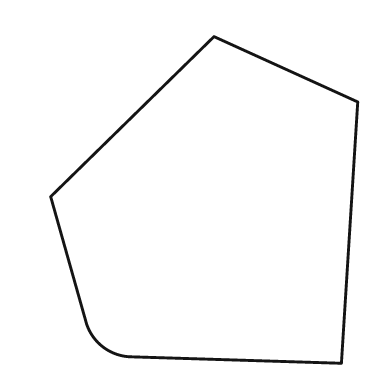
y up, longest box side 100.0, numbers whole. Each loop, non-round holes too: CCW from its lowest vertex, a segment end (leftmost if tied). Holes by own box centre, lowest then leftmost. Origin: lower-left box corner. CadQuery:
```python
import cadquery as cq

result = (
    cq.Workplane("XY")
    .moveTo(89.0, 0.0)
    .lineTo(94.0, 80.0)
    .lineTo(50.0, 100.0)
    .lineTo(0.0, 51.0)
    .lineTo(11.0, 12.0)
    .threePointArc((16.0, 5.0), (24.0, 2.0))
    .close()
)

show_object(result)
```